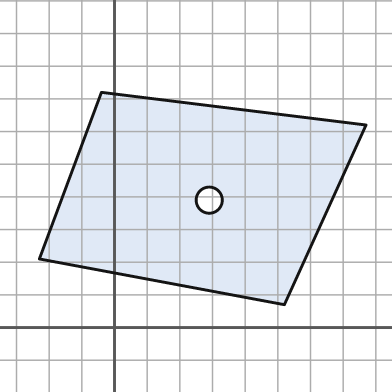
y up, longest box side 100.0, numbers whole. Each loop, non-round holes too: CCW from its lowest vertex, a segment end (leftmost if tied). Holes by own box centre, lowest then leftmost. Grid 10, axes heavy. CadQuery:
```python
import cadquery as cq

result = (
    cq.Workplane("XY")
    .moveTo(52.0, 7.0)
    .lineTo(77.0, 62.0)
    .lineTo(-4.0, 72.0)
    .lineTo(-23.0, 21.0)
    .close()
    .moveTo(29.0, 39.0)
    .circle(4.0)
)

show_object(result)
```